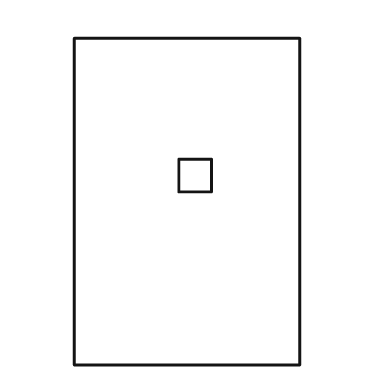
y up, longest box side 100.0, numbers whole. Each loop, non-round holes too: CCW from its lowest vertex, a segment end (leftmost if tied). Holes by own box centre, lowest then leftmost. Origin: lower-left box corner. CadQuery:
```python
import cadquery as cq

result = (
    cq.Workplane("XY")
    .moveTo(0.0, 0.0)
    .lineTo(69.0, 0.0)
    .lineTo(69.0, 100.0)
    .lineTo(0.0, 100.0)
    .close()
    .moveTo(32.0, 53.0)
    .lineTo(42.0, 53.0)
    .lineTo(42.0, 63.0)
    .lineTo(32.0, 63.0)
    .close()
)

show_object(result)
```